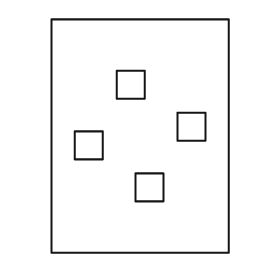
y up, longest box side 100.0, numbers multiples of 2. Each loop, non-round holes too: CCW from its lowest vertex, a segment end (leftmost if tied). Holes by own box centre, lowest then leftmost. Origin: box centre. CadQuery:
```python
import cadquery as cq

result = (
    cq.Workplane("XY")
    .moveTo(-38.0, -50.0)
    .lineTo(38.0, -50.0)
    .lineTo(38.0, 50.0)
    .lineTo(-38.0, 50.0)
    .close()
    .moveTo(-2.0, -28.0)
    .lineTo(10.0, -28.0)
    .lineTo(10.0, -16.0)
    .lineTo(-2.0, -16.0)
    .close()
    .moveTo(-28.0, -10.0)
    .lineTo(-16.0, -10.0)
    .lineTo(-16.0, 2.0)
    .lineTo(-28.0, 2.0)
    .close()
    .moveTo(16.0, -2.0)
    .lineTo(28.0, -2.0)
    .lineTo(28.0, 10.0)
    .lineTo(16.0, 10.0)
    .close()
    .moveTo(-10.0, 16.0)
    .lineTo(2.0, 16.0)
    .lineTo(2.0, 28.0)
    .lineTo(-10.0, 28.0)
    .close()
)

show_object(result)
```